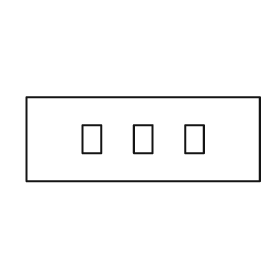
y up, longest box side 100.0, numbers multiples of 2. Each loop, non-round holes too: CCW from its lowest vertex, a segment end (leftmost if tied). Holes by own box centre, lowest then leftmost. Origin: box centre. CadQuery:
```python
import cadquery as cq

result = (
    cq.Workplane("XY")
    .moveTo(-50.0, -18.0)
    .lineTo(50.0, -18.0)
    .lineTo(50.0, 18.0)
    .lineTo(-50.0, 18.0)
    .close()
    .moveTo(-26.0, -6.0)
    .lineTo(-18.0, -6.0)
    .lineTo(-18.0, 6.0)
    .lineTo(-26.0, 6.0)
    .close()
    .moveTo(-4.0, -6.0)
    .lineTo(4.0, -6.0)
    .lineTo(4.0, 6.0)
    .lineTo(-4.0, 6.0)
    .close()
    .moveTo(18.0, -6.0)
    .lineTo(26.0, -6.0)
    .lineTo(26.0, 6.0)
    .lineTo(18.0, 6.0)
    .close()
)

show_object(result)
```